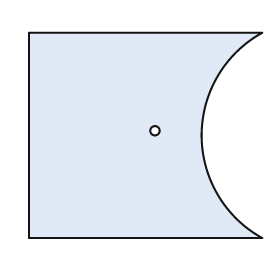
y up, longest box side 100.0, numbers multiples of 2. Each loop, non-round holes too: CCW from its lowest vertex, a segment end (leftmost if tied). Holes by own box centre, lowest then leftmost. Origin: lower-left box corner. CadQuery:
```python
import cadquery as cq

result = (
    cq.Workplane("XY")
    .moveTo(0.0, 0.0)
    .lineTo(100.0, 0.0)
    .threePointArc((74.0, 44.0), (100.0, 88.0))
    .lineTo(0.0, 88.0)
    .close()
    .moveTo(54.0, 46.0)
    .circle(2.0)
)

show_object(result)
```